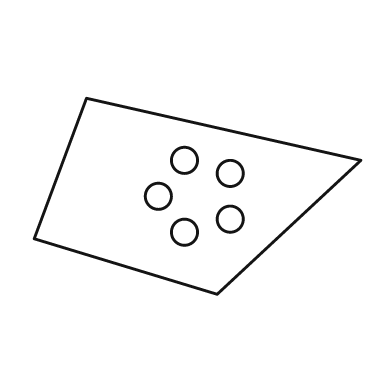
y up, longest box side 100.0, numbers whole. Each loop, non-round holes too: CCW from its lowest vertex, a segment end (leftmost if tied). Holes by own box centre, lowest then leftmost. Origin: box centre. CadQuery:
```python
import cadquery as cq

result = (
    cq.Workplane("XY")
    .moveTo(6.0, -30.0)
    .lineTo(50.0, 11.0)
    .lineTo(-34.0, 30.0)
    .lineTo(-50.0, -13.0)
    .close()
    .moveTo(-4.0, -11.0)
    .circle(4.0)
    .moveTo(10.0, -7.0)
    .circle(4.0)
    .moveTo(-12.0, 0.0)
    .circle(4.0)
    .moveTo(10.0, 7.0)
    .circle(4.0)
    .moveTo(-4.0, 11.0)
    .circle(4.0)
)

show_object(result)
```